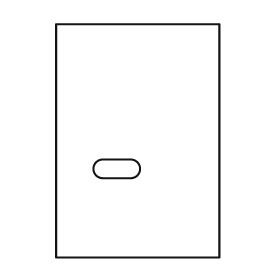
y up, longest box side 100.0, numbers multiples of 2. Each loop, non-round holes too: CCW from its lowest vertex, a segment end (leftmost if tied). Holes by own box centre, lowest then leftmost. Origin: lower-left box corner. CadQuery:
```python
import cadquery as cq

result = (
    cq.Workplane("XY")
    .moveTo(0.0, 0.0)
    .lineTo(70.0, 0.0)
    .lineTo(70.0, 100.0)
    .lineTo(0.0, 100.0)
    .close()
    .moveTo(20.0, 34.0)
    .lineTo(32.0, 34.0)
    .threePointArc((36.0, 38.0), (32.0, 42.0))
    .lineTo(20.0, 42.0)
    .threePointArc((16.0, 38.0), (20.0, 34.0))
    .close()
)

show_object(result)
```